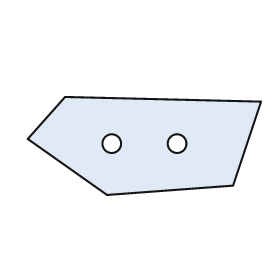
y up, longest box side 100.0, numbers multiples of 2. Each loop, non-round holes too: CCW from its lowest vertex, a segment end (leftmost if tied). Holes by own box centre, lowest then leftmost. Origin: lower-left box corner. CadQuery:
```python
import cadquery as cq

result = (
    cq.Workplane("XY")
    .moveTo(34.0, 0.0)
    .lineTo(88.0, 4.0)
    .lineTo(100.0, 40.0)
    .lineTo(16.0, 42.0)
    .lineTo(0.0, 24.0)
    .close()
    .moveTo(36.0, 22.0)
    .circle(4.0)
    .moveTo(64.0, 22.0)
    .circle(4.0)
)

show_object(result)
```